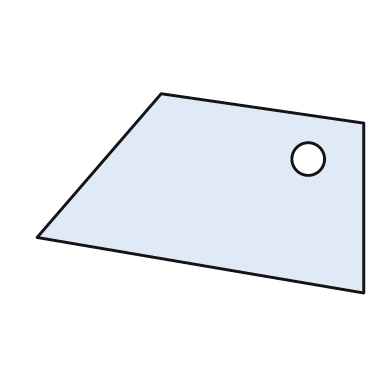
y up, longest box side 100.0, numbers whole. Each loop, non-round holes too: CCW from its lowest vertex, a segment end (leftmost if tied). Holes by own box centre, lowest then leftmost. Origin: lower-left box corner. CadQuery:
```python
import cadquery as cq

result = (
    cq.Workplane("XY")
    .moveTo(100.0, 0.0)
    .lineTo(100.0, 52.0)
    .lineTo(38.0, 61.0)
    .lineTo(0.0, 17.0)
    .close()
    .moveTo(83.0, 41.0)
    .circle(5.0)
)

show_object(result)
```